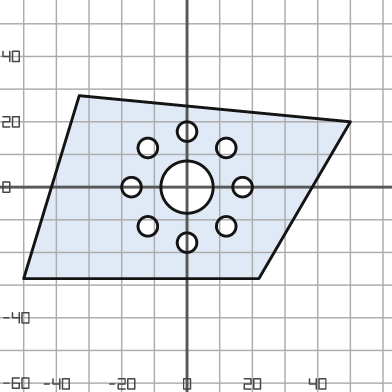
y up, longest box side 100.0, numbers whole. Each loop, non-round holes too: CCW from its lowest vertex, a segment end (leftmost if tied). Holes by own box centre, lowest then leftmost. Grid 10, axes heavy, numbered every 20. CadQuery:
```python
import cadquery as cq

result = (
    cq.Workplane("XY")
    .moveTo(-50.0, -28.0)
    .lineTo(22.0, -28.0)
    .lineTo(50.0, 20.0)
    .lineTo(-33.0, 28.0)
    .close()
    .moveTo(0.0, -17.0)
    .circle(3.0)
    .moveTo(-12.0, -12.0)
    .circle(3.0)
    .moveTo(12.0, -12.0)
    .circle(3.0)
    .moveTo(-17.0, 0.0)
    .circle(3.0)
    .moveTo(0.0, 0.0)
    .circle(8.0)
    .moveTo(17.0, 0.0)
    .circle(3.0)
    .moveTo(-12.0, 12.0)
    .circle(3.0)
    .moveTo(12.0, 12.0)
    .circle(3.0)
    .moveTo(0.0, 17.0)
    .circle(3.0)
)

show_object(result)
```